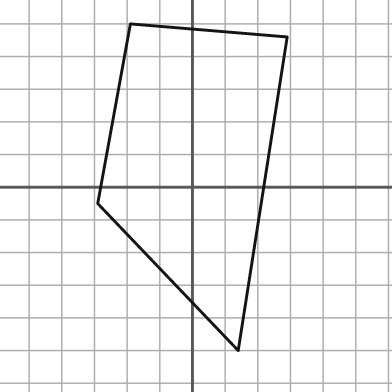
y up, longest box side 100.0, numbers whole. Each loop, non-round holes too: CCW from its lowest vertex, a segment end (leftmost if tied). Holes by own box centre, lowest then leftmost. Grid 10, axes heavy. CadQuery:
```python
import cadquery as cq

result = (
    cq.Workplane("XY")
    .moveTo(14.0, -50.0)
    .lineTo(29.0, 46.0)
    .lineTo(-19.0, 50.0)
    .lineTo(-29.0, -5.0)
    .close()
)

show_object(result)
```